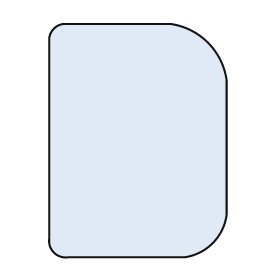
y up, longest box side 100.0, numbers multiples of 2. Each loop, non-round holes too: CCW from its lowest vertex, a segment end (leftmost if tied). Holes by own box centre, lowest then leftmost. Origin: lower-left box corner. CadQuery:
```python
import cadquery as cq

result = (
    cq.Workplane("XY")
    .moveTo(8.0, 0.0)
    .lineTo(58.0, 0.0)
    .threePointArc((70.0, 6.0), (76.0, 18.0))
    .lineTo(76.0, 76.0)
    .threePointArc((68.0, 92.0), (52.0, 100.0))
    .lineTo(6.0, 100.0)
    .threePointArc((2.0, 98.0), (0.0, 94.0))
    .lineTo(0.0, 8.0)
    .threePointArc((2.0, 2.0), (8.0, 0.0))
    .close()
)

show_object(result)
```